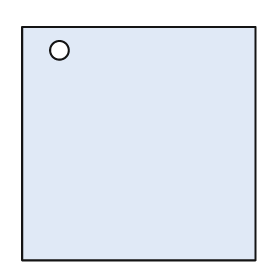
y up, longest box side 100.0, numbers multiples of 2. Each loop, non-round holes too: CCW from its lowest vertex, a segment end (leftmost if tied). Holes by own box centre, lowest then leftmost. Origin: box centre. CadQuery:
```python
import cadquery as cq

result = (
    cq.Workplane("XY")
    .moveTo(-50.0, -50.0)
    .lineTo(50.0, -50.0)
    .lineTo(50.0, 50.0)
    .lineTo(-50.0, 50.0)
    .close()
    .moveTo(-34.0, 40.0)
    .circle(4.0)
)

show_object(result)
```